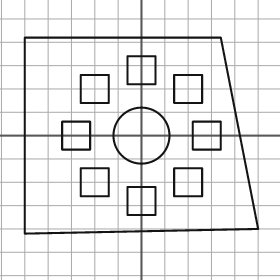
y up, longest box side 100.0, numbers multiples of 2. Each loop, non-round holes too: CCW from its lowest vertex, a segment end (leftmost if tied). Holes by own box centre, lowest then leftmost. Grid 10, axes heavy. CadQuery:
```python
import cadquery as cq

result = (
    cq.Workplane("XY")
    .moveTo(-50.0, -42.0)
    .lineTo(50.0, -40.0)
    .lineTo(34.0, 42.0)
    .lineTo(-50.0, 42.0)
    .close()
    .moveTo(-6.0, -34.0)
    .lineTo(6.0, -34.0)
    .lineTo(6.0, -22.0)
    .lineTo(-6.0, -22.0)
    .close()
    .moveTo(-26.0, -26.0)
    .lineTo(-14.0, -26.0)
    .lineTo(-14.0, -14.0)
    .lineTo(-26.0, -14.0)
    .close()
    .moveTo(14.0, -26.0)
    .lineTo(26.0, -26.0)
    .lineTo(26.0, -14.0)
    .lineTo(14.0, -14.0)
    .close()
    .moveTo(-34.0, -6.0)
    .lineTo(-22.0, -6.0)
    .lineTo(-22.0, 6.0)
    .lineTo(-34.0, 6.0)
    .close()
    .moveTo(0.0, 0.0)
    .circle(12.0)
    .moveTo(22.0, -6.0)
    .lineTo(34.0, -6.0)
    .lineTo(34.0, 6.0)
    .lineTo(22.0, 6.0)
    .close()
    .moveTo(-26.0, 14.0)
    .lineTo(-14.0, 14.0)
    .lineTo(-14.0, 26.0)
    .lineTo(-26.0, 26.0)
    .close()
    .moveTo(14.0, 14.0)
    .lineTo(26.0, 14.0)
    .lineTo(26.0, 26.0)
    .lineTo(14.0, 26.0)
    .close()
    .moveTo(-6.0, 22.0)
    .lineTo(6.0, 22.0)
    .lineTo(6.0, 34.0)
    .lineTo(-6.0, 34.0)
    .close()
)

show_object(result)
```